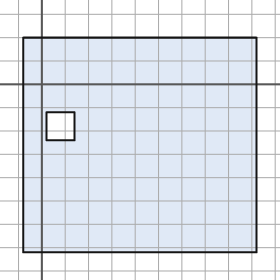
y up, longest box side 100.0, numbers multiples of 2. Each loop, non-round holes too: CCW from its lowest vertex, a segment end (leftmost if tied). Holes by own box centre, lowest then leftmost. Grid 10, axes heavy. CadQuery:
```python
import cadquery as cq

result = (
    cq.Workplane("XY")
    .moveTo(-8.0, -72.0)
    .lineTo(92.0, -72.0)
    .lineTo(92.0, 20.0)
    .lineTo(-8.0, 20.0)
    .close()
    .moveTo(2.0, -24.0)
    .lineTo(14.0, -24.0)
    .lineTo(14.0, -12.0)
    .lineTo(2.0, -12.0)
    .close()
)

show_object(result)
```